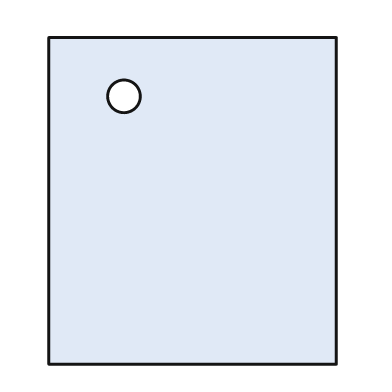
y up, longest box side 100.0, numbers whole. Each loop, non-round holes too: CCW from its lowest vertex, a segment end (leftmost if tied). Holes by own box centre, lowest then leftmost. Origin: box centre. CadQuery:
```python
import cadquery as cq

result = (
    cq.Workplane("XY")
    .moveTo(-44.0, -50.0)
    .lineTo(44.0, -50.0)
    .lineTo(44.0, 50.0)
    .lineTo(-44.0, 50.0)
    .close()
    .moveTo(-21.0, 32.0)
    .circle(5.0)
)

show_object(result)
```